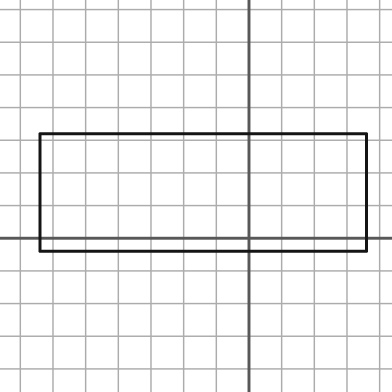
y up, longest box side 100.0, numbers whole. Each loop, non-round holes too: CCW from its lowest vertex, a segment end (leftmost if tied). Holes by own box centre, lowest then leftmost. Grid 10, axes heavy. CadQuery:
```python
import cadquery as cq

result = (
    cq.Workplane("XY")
    .moveTo(-64.0, -4.0)
    .lineTo(36.0, -4.0)
    .lineTo(36.0, 32.0)
    .lineTo(-64.0, 32.0)
    .close()
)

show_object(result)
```